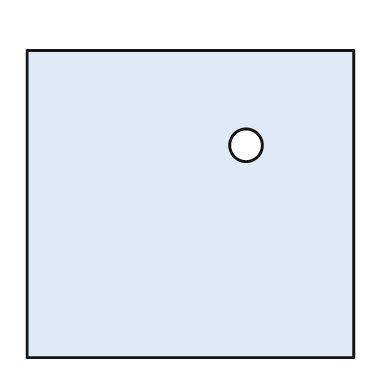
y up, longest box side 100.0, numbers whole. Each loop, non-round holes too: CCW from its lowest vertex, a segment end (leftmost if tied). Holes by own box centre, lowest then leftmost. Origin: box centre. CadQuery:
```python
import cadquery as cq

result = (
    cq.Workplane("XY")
    .moveTo(-50.0, -47.0)
    .lineTo(50.0, -47.0)
    .lineTo(50.0, 47.0)
    .lineTo(-50.0, 47.0)
    .close()
    .moveTo(17.0, 18.0)
    .circle(5.0)
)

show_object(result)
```